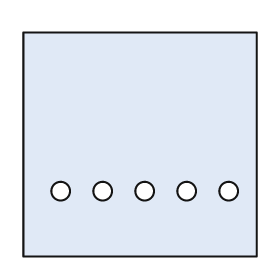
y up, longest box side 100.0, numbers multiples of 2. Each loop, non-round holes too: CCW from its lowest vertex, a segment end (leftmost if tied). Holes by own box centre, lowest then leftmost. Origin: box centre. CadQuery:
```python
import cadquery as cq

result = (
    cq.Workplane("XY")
    .moveTo(-50.0, -48.0)
    .lineTo(50.0, -48.0)
    .lineTo(50.0, 48.0)
    .lineTo(-50.0, 48.0)
    .close()
    .moveTo(-34.0, -20.0)
    .circle(4.0)
    .moveTo(-16.0, -20.0)
    .circle(4.0)
    .moveTo(2.0, -20.0)
    .circle(4.0)
    .moveTo(20.0, -20.0)
    .circle(4.0)
    .moveTo(38.0, -20.0)
    .circle(4.0)
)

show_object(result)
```